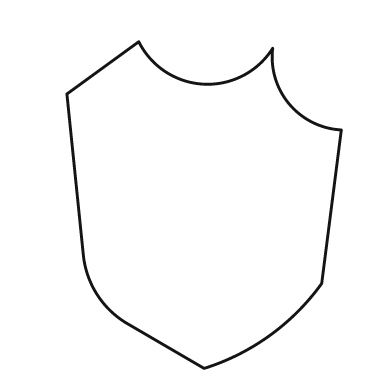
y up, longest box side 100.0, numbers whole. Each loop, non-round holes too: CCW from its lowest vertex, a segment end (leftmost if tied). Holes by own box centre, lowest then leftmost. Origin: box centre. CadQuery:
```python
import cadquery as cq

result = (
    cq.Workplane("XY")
    .moveTo(0.0, -50.0)
    .threePointArc((20.0, -40.0), (36.0, -24.0))
    .lineTo(42.0, 23.0)
    .threePointArc((26.0, 31.0), (21.0, 48.0))
    .threePointArc((0.0, 37.0), (-20.0, 50.0))
    .lineTo(-42.0, 34.0)
    .lineTo(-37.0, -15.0)
    .threePointArc((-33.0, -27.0), (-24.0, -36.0))
    .close()
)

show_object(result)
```